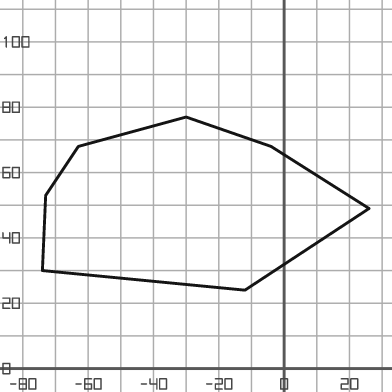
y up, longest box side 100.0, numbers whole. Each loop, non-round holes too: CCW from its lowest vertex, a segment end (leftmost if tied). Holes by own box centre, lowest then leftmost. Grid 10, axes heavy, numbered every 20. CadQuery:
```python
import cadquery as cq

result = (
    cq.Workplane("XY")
    .moveTo(-12.0, 24.0)
    .lineTo(26.0, 49.0)
    .lineTo(-4.0, 68.0)
    .lineTo(-30.0, 77.0)
    .lineTo(-63.0, 68.0)
    .lineTo(-73.0, 53.0)
    .lineTo(-74.0, 30.0)
    .close()
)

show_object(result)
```